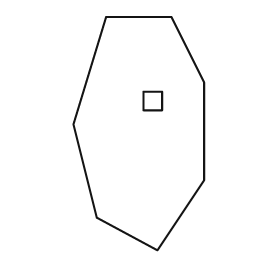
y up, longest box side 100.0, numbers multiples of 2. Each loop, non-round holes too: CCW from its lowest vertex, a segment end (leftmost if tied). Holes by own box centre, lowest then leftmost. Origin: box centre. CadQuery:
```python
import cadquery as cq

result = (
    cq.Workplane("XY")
    .moveTo(8.0, -50.0)
    .lineTo(28.0, -20.0)
    .lineTo(28.0, 22.0)
    .lineTo(14.0, 50.0)
    .lineTo(-14.0, 50.0)
    .lineTo(-28.0, 4.0)
    .lineTo(-18.0, -36.0)
    .close()
    .moveTo(2.0, 10.0)
    .lineTo(10.0, 10.0)
    .lineTo(10.0, 18.0)
    .lineTo(2.0, 18.0)
    .close()
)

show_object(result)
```